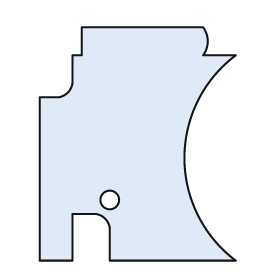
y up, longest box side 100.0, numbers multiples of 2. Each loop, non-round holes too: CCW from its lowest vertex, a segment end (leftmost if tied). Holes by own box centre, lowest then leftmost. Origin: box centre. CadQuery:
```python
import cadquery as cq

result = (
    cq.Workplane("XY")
    .moveTo(-42.0, -50.0)
    .lineTo(-28.0, -50.0)
    .lineTo(-28.0, -30.0)
    .lineTo(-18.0, -30.0)
    .threePointArc((-14.0, -32.0), (-12.0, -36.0))
    .lineTo(-12.0, -50.0)
    .lineTo(42.0, -50.0)
    .threePointArc((20.0, -6.0), (42.0, 38.0))
    .lineTo(28.0, 38.0)
    .threePointArc((30.0, 44.0), (28.0, 50.0))
    .lineTo(-24.0, 50.0)
    .lineTo(-24.0, 38.0)
    .lineTo(-28.0, 38.0)
    .lineTo(-28.0, 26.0)
    .threePointArc((-30.0, 22.0), (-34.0, 20.0))
    .lineTo(-42.0, 20.0)
    .close()
    .moveTo(-12.0, -24.0)
    .circle(4.0)
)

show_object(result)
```